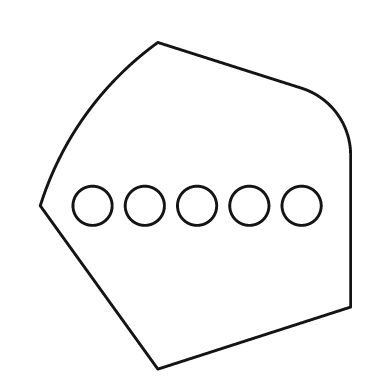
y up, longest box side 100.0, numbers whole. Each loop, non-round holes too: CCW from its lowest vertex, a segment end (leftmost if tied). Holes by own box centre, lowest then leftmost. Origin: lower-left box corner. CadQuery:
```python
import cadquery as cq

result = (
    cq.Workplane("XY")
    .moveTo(36.0, 0.0)
    .lineTo(95.0, 19.0)
    .lineTo(95.0, 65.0)
    .threePointArc((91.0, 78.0), (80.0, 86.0))
    .lineTo(36.0, 100.0)
    .threePointArc((14.0, 78.0), (0.0, 50.0))
    .close()
    .moveTo(16.0, 50.0)
    .circle(6.0)
    .moveTo(32.0, 50.0)
    .circle(6.0)
    .moveTo(48.0, 50.0)
    .circle(6.0)
    .moveTo(64.0, 50.0)
    .circle(6.0)
    .moveTo(80.0, 50.0)
    .circle(6.0)
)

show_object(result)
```